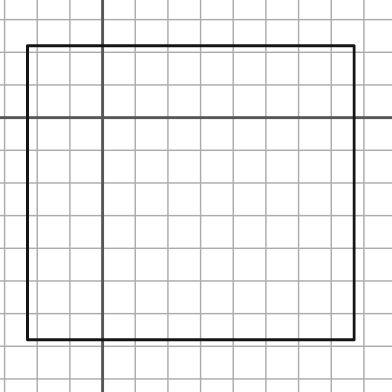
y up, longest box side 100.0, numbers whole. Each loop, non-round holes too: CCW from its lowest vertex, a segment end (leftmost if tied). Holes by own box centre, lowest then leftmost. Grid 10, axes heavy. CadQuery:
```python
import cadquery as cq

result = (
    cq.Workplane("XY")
    .moveTo(-23.0, -68.0)
    .lineTo(77.0, -68.0)
    .lineTo(77.0, 22.0)
    .lineTo(-23.0, 22.0)
    .close()
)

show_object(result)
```